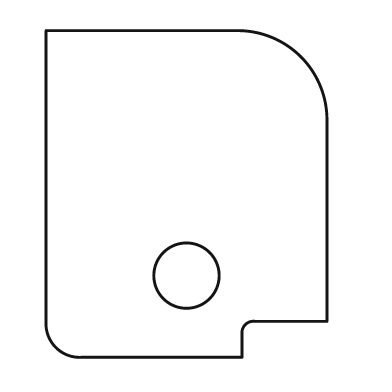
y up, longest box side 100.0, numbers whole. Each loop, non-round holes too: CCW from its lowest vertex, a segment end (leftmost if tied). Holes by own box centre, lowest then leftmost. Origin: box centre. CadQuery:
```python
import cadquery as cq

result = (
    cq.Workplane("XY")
    .moveTo(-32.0, -50.0)
    .lineTo(17.0, -50.0)
    .lineTo(17.0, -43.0)
    .threePointArc((18.0, -40.0), (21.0, -39.0))
    .lineTo(43.0, -39.0)
    .lineTo(43.0, 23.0)
    .threePointArc((35.0, 42.0), (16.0, 50.0))
    .lineTo(-43.0, 50.0)
    .lineTo(-43.0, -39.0)
    .threePointArc((-40.0, -47.0), (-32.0, -50.0))
    .close()
    .moveTo(0.0, -25.0)
    .circle(10.0)
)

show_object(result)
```